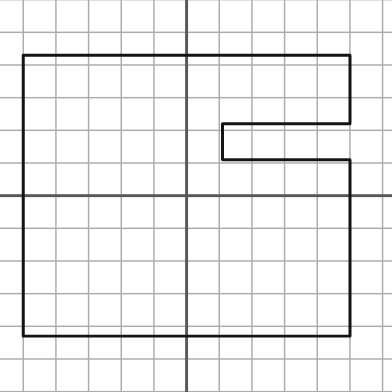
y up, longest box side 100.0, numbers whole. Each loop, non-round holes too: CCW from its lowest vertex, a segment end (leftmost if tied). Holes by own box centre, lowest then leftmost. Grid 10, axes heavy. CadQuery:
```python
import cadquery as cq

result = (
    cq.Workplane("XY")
    .moveTo(-50.0, -43.0)
    .lineTo(50.0, -43.0)
    .lineTo(50.0, 11.0)
    .lineTo(11.0, 11.0)
    .lineTo(11.0, 22.0)
    .lineTo(50.0, 22.0)
    .lineTo(50.0, 43.0)
    .lineTo(-50.0, 43.0)
    .close()
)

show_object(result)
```